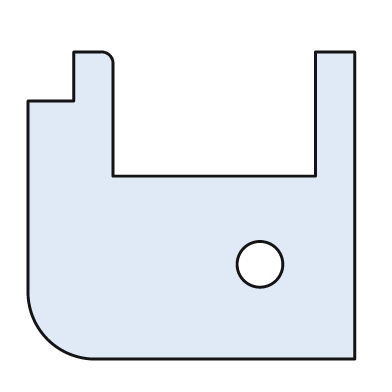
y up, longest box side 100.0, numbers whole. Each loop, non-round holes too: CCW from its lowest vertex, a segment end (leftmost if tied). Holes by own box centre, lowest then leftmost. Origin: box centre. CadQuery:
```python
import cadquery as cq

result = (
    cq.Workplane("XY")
    .moveTo(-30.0, -47.0)
    .lineTo(50.0, -47.0)
    .lineTo(50.0, 47.0)
    .lineTo(38.0, 47.0)
    .lineTo(38.0, 9.0)
    .lineTo(-24.0, 9.0)
    .lineTo(-24.0, 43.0)
    .threePointArc((-25.0, 46.0), (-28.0, 47.0))
    .lineTo(-36.0, 47.0)
    .lineTo(-36.0, 32.0)
    .lineTo(-50.0, 32.0)
    .lineTo(-50.0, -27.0)
    .threePointArc((-44.0, -41.0), (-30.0, -47.0))
    .close()
    .moveTo(21.0, -18.0)
    .circle(7.0)
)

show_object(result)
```